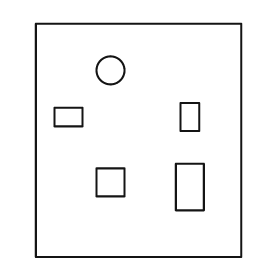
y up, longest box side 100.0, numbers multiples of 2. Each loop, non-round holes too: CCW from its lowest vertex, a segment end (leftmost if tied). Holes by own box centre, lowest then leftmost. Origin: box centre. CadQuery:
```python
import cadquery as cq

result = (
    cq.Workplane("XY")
    .moveTo(-44.0, -50.0)
    .lineTo(44.0, -50.0)
    .lineTo(44.0, 50.0)
    .lineTo(-44.0, 50.0)
    .close()
    .moveTo(16.0, -30.0)
    .lineTo(28.0, -30.0)
    .lineTo(28.0, -10.0)
    .lineTo(16.0, -10.0)
    .close()
    .moveTo(-18.0, -24.0)
    .lineTo(-6.0, -24.0)
    .lineTo(-6.0, -12.0)
    .lineTo(-18.0, -12.0)
    .close()
    .moveTo(-36.0, 6.0)
    .lineTo(-24.0, 6.0)
    .lineTo(-24.0, 14.0)
    .lineTo(-36.0, 14.0)
    .close()
    .moveTo(18.0, 4.0)
    .lineTo(26.0, 4.0)
    .lineTo(26.0, 16.0)
    .lineTo(18.0, 16.0)
    .close()
    .moveTo(-12.0, 30.0)
    .circle(6.0)
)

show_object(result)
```